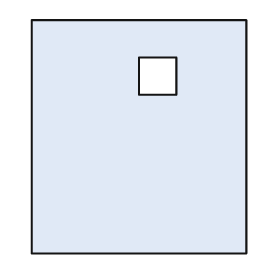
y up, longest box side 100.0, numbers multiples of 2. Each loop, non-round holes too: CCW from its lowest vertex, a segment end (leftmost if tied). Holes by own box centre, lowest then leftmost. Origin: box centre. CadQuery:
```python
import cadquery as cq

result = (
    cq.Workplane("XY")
    .moveTo(-46.0, -50.0)
    .lineTo(46.0, -50.0)
    .lineTo(46.0, 50.0)
    .lineTo(-46.0, 50.0)
    .close()
    .moveTo(0.0, 18.0)
    .lineTo(16.0, 18.0)
    .lineTo(16.0, 34.0)
    .lineTo(0.0, 34.0)
    .close()
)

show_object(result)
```